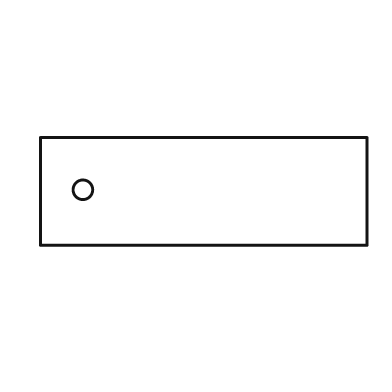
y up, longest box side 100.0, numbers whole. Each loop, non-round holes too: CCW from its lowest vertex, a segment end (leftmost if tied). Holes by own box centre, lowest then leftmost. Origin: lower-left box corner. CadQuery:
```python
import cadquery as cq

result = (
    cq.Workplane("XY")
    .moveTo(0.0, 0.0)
    .lineTo(100.0, 0.0)
    .lineTo(100.0, 33.0)
    .lineTo(0.0, 33.0)
    .close()
    .moveTo(13.0, 17.0)
    .circle(3.0)
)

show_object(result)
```